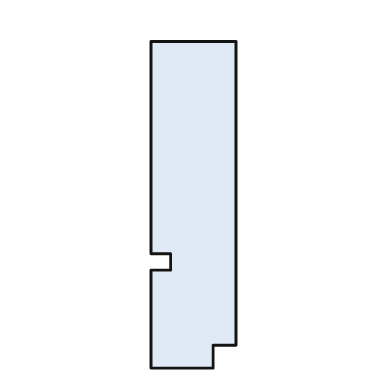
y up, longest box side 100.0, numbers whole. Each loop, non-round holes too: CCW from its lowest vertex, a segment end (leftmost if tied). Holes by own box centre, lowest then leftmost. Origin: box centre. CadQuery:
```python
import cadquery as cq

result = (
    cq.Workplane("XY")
    .moveTo(-13.0, -50.0)
    .lineTo(6.0, -50.0)
    .lineTo(6.0, -43.0)
    .lineTo(13.0, -43.0)
    .lineTo(13.0, 50.0)
    .lineTo(-13.0, 50.0)
    .lineTo(-13.0, -15.0)
    .lineTo(-7.0, -15.0)
    .lineTo(-7.0, -20.0)
    .lineTo(-13.0, -20.0)
    .close()
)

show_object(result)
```